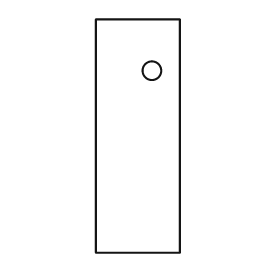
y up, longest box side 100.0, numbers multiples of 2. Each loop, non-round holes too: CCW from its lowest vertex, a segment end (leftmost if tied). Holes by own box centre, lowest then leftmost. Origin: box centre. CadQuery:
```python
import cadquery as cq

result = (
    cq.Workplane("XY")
    .moveTo(-18.0, -50.0)
    .lineTo(18.0, -50.0)
    .lineTo(18.0, 50.0)
    .lineTo(-18.0, 50.0)
    .close()
    .moveTo(6.0, 28.0)
    .circle(4.0)
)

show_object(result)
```